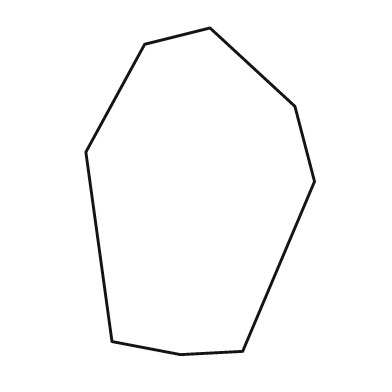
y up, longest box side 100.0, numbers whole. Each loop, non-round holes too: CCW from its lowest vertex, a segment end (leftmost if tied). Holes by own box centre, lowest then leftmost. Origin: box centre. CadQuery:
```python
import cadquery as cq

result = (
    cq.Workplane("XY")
    .moveTo(-6.0, -50.0)
    .lineTo(13.0, -49.0)
    .lineTo(35.0, 3.0)
    .lineTo(29.0, 26.0)
    .lineTo(3.0, 50.0)
    .lineTo(-17.0, 45.0)
    .lineTo(-35.0, 12.0)
    .lineTo(-27.0, -46.0)
    .close()
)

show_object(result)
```